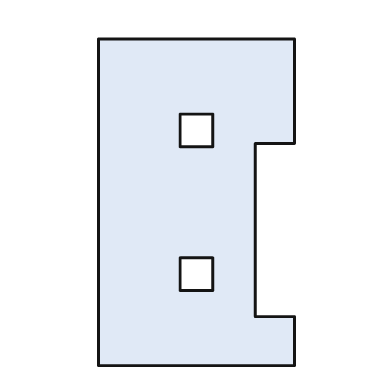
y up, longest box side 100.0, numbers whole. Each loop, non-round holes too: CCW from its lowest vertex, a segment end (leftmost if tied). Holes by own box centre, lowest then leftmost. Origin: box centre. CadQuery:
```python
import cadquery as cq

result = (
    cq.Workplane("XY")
    .moveTo(-30.0, -50.0)
    .lineTo(30.0, -50.0)
    .lineTo(30.0, -35.0)
    .lineTo(18.0, -35.0)
    .lineTo(18.0, 18.0)
    .lineTo(30.0, 18.0)
    .lineTo(30.0, 50.0)
    .lineTo(-30.0, 50.0)
    .close()
    .moveTo(-5.0, -27.0)
    .lineTo(5.0, -27.0)
    .lineTo(5.0, -17.0)
    .lineTo(-5.0, -17.0)
    .close()
    .moveTo(-5.0, 17.0)
    .lineTo(5.0, 17.0)
    .lineTo(5.0, 27.0)
    .lineTo(-5.0, 27.0)
    .close()
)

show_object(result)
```